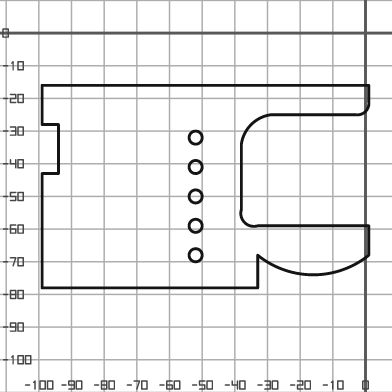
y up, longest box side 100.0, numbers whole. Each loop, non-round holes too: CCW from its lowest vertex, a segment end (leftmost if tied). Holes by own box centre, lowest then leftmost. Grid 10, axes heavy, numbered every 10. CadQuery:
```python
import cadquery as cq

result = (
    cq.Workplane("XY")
    .moveTo(-99.0, -78.0)
    .lineTo(-33.0, -78.0)
    .lineTo(-33.0, -68.0)
    .threePointArc((-16.0, -74.0), (1.0, -68.0))
    .lineTo(1.0, -59.0)
    .lineTo(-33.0, -59.0)
    .threePointArc((-37.0, -58.0), (-38.0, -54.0))
    .lineTo(-38.0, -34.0)
    .threePointArc((-35.0, -28.0), (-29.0, -25.0))
    .lineTo(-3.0, -25.0)
    .threePointArc((0.0, -24.0), (1.0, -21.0))
    .lineTo(1.0, -16.0)
    .lineTo(-99.0, -16.0)
    .lineTo(-99.0, -28.0)
    .lineTo(-94.0, -28.0)
    .lineTo(-94.0, -43.0)
    .lineTo(-99.0, -43.0)
    .close()
    .moveTo(-52.0, -68.0)
    .circle(2.0)
    .moveTo(-52.0, -59.0)
    .circle(2.0)
    .moveTo(-52.0, -50.0)
    .circle(2.0)
    .moveTo(-52.0, -41.0)
    .circle(2.0)
    .moveTo(-52.0, -32.0)
    .circle(2.0)
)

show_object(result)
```